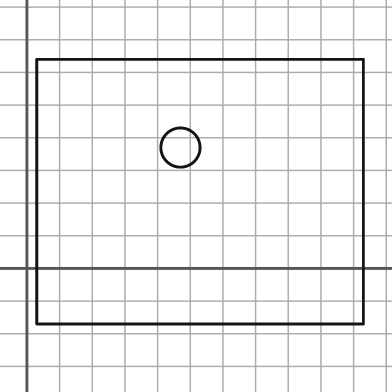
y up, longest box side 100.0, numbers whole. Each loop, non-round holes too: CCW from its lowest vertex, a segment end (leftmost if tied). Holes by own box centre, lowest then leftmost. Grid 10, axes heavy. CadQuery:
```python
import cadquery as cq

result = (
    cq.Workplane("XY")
    .moveTo(3.0, -17.0)
    .lineTo(103.0, -17.0)
    .lineTo(103.0, 64.0)
    .lineTo(3.0, 64.0)
    .close()
    .moveTo(47.0, 37.0)
    .circle(6.0)
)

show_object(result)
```